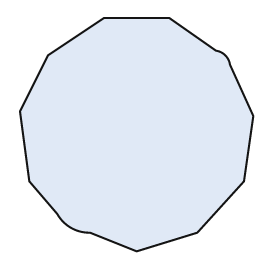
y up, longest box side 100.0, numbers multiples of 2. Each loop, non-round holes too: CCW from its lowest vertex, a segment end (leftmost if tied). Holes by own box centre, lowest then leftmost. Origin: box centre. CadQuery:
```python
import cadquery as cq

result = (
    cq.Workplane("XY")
    .moveTo(0.0, -50.0)
    .lineTo(26.0, -42.0)
    .lineTo(46.0, -20.0)
    .lineTo(50.0, 8.0)
    .lineTo(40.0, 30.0)
    .threePointArc((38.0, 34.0), (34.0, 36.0))
    .lineTo(14.0, 50.0)
    .lineTo(-14.0, 50.0)
    .lineTo(-38.0, 34.0)
    .lineTo(-50.0, 10.0)
    .lineTo(-46.0, -20.0)
    .lineTo(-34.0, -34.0)
    .threePointArc((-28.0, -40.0), (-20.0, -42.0))
    .close()
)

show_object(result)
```